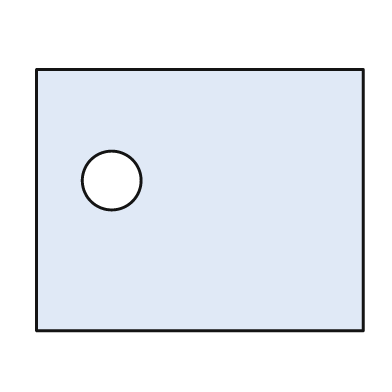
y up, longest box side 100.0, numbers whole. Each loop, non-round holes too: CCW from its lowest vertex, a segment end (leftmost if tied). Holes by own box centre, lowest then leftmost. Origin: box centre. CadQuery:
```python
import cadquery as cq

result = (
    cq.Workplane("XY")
    .moveTo(-50.0, -40.0)
    .lineTo(50.0, -40.0)
    .lineTo(50.0, 40.0)
    .lineTo(-50.0, 40.0)
    .close()
    .moveTo(-27.0, 6.0)
    .circle(9.0)
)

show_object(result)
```